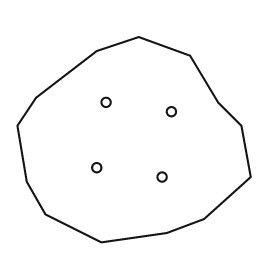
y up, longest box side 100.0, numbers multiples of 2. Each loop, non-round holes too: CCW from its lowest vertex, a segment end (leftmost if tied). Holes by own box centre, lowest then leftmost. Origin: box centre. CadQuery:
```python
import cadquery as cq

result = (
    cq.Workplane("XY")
    .moveTo(-14.0, -44.0)
    .lineTo(14.0, -40.0)
    .lineTo(30.0, -34.0)
    .lineTo(50.0, -16.0)
    .lineTo(46.0, 6.0)
    .lineTo(36.0, 16.0)
    .lineTo(24.0, 36.0)
    .lineTo(2.0, 44.0)
    .lineTo(-16.0, 38.0)
    .lineTo(-42.0, 18.0)
    .lineTo(-50.0, 6.0)
    .lineTo(-46.0, -18.0)
    .lineTo(-38.0, -32.0)
    .close()
    .moveTo(12.0, -16.0)
    .circle(2.0)
    .moveTo(-16.0, -12.0)
    .circle(2.0)
    .moveTo(16.0, 12.0)
    .circle(2.0)
    .moveTo(-12.0, 16.0)
    .circle(2.0)
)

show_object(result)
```